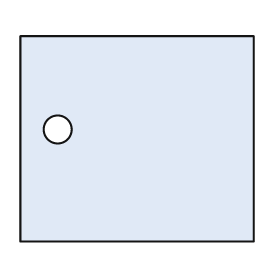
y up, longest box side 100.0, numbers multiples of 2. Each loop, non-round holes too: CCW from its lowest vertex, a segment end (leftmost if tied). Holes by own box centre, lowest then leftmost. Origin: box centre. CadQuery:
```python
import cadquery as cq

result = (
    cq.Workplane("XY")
    .moveTo(-50.0, -44.0)
    .lineTo(50.0, -44.0)
    .lineTo(50.0, 44.0)
    .lineTo(-50.0, 44.0)
    .close()
    .moveTo(-34.0, 4.0)
    .circle(6.0)
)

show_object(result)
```